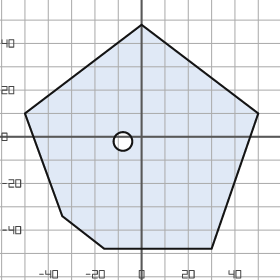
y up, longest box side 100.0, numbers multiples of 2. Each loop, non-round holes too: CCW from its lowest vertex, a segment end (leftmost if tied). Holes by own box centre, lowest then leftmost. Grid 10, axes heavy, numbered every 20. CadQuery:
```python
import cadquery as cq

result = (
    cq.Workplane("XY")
    .moveTo(-16.0, -48.0)
    .lineTo(30.0, -48.0)
    .lineTo(50.0, 10.0)
    .lineTo(0.0, 48.0)
    .lineTo(-50.0, 10.0)
    .lineTo(-34.0, -34.0)
    .close()
    .moveTo(-8.0, -2.0)
    .circle(4.0)
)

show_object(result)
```